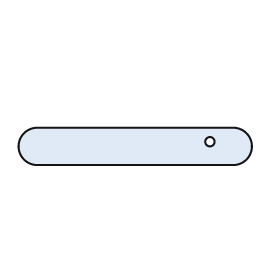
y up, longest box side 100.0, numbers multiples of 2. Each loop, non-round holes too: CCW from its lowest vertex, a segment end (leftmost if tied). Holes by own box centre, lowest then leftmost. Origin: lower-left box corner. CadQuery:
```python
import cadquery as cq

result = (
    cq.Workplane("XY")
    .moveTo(8.0, 0.0)
    .lineTo(92.0, 0.0)
    .threePointArc((100.0, 8.0), (92.0, 16.0))
    .lineTo(8.0, 16.0)
    .threePointArc((0.0, 8.0), (8.0, 0.0))
    .close()
    .moveTo(82.0, 10.0)
    .circle(2.0)
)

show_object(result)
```